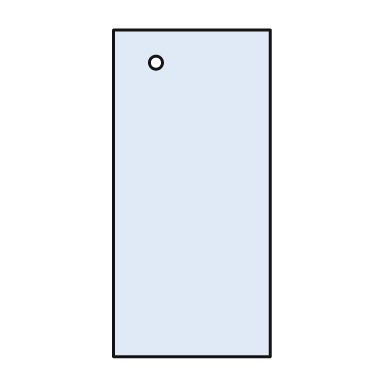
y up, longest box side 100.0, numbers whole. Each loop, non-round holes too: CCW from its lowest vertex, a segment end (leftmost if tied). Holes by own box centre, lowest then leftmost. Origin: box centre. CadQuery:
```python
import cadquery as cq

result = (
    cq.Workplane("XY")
    .moveTo(-24.0, -50.0)
    .lineTo(24.0, -50.0)
    .lineTo(24.0, 50.0)
    .lineTo(-24.0, 50.0)
    .close()
    .moveTo(-11.0, 40.0)
    .circle(2.0)
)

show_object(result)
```